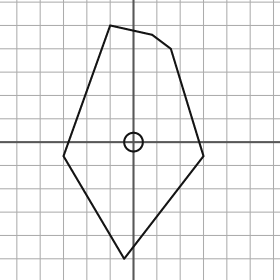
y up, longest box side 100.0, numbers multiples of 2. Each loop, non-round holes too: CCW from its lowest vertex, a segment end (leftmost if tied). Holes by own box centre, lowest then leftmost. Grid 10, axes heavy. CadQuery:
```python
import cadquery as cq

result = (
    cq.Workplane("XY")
    .moveTo(-4.0, -50.0)
    .lineTo(30.0, -6.0)
    .lineTo(16.0, 40.0)
    .lineTo(8.0, 46.0)
    .lineTo(-10.0, 50.0)
    .lineTo(-30.0, -6.0)
    .close()
    .moveTo(0.0, 0.0)
    .circle(4.0)
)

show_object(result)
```